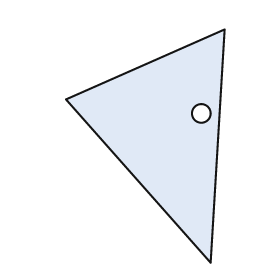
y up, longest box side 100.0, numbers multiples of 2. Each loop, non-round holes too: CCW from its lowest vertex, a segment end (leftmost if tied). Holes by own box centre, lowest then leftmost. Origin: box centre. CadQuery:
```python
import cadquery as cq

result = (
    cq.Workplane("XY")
    .moveTo(28.0, -50.0)
    .lineTo(34.0, 50.0)
    .lineTo(-34.0, 20.0)
    .close()
    .moveTo(24.0, 14.0)
    .circle(4.0)
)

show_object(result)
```